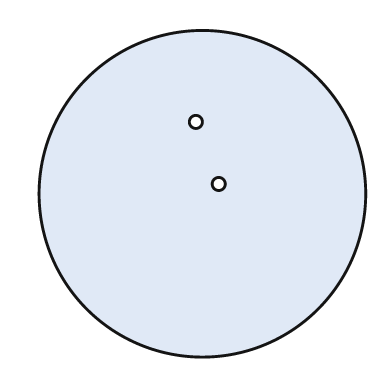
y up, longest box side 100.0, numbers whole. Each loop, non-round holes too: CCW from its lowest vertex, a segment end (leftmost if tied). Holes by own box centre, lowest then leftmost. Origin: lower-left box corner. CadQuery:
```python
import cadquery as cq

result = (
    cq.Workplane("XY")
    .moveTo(50.0, 50.0)
    .circle(50.0)
    .moveTo(55.0, 53.0)
    .circle(2.0)
    .moveTo(48.0, 72.0)
    .circle(2.0)
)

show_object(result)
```